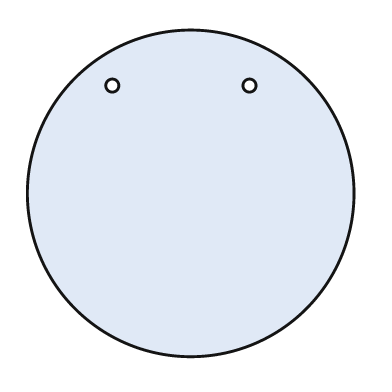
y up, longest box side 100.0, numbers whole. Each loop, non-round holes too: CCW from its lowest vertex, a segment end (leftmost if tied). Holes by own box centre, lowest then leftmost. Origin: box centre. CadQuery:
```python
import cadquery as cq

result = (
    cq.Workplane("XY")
    .moveTo(0.0, 0.0)
    .circle(50.0)
    .moveTo(-24.0, 33.0)
    .circle(2.0)
    .moveTo(18.0, 33.0)
    .circle(2.0)
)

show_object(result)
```